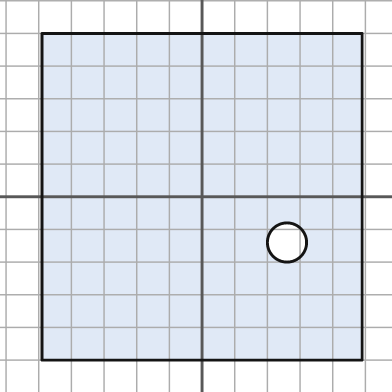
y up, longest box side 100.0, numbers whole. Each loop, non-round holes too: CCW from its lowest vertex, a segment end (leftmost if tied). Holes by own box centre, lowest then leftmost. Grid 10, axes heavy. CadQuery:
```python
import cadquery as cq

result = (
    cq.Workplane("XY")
    .moveTo(-49.0, -50.0)
    .lineTo(49.0, -50.0)
    .lineTo(49.0, 50.0)
    .lineTo(-49.0, 50.0)
    .close()
    .moveTo(26.0, -14.0)
    .circle(6.0)
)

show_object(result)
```